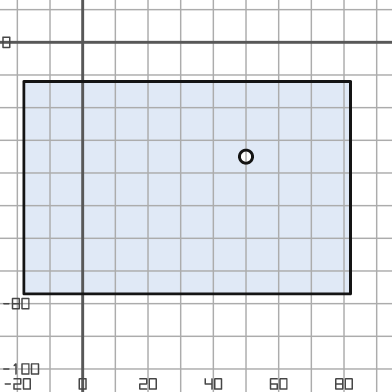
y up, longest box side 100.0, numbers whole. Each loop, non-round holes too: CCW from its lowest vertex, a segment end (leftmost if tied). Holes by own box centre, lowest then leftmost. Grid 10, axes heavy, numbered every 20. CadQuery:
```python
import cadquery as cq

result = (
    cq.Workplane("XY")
    .moveTo(-18.0, -77.0)
    .lineTo(82.0, -77.0)
    .lineTo(82.0, -12.0)
    .lineTo(-18.0, -12.0)
    .close()
    .moveTo(50.0, -35.0)
    .circle(2.0)
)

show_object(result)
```